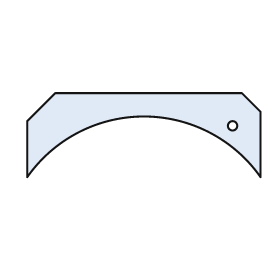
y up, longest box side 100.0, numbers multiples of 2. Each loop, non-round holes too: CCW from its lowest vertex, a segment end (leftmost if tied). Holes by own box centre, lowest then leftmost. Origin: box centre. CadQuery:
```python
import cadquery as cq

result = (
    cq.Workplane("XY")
    .moveTo(-50.0, -18.0)
    .threePointArc((0.0, 8.0), (50.0, -18.0))
    .lineTo(50.0, 10.0)
    .lineTo(42.0, 18.0)
    .lineTo(-38.0, 18.0)
    .lineTo(-50.0, 6.0)
    .close()
    .moveTo(38.0, 4.0)
    .circle(2.0)
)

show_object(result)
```